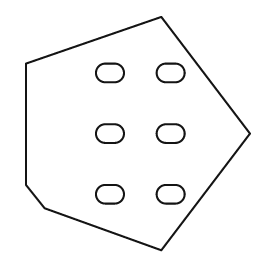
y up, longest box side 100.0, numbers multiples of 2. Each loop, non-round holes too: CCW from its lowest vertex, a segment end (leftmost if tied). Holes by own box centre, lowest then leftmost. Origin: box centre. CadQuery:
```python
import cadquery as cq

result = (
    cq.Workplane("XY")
    .moveTo(10.0, -50.0)
    .lineTo(48.0, 0.0)
    .lineTo(10.0, 50.0)
    .lineTo(-48.0, 30.0)
    .lineTo(-48.0, -22.0)
    .lineTo(-40.0, -32.0)
    .close()
    .moveTo(-14.0, -30.0)
    .lineTo(-10.0, -30.0)
    .threePointArc((-6.0, -26.0), (-10.0, -22.0))
    .lineTo(-14.0, -22.0)
    .threePointArc((-18.0, -26.0), (-14.0, -30.0))
    .close()
    .moveTo(12.0, -30.0)
    .lineTo(16.0, -30.0)
    .threePointArc((20.0, -26.0), (16.0, -22.0))
    .lineTo(12.0, -22.0)
    .threePointArc((8.0, -26.0), (12.0, -30.0))
    .close()
    .moveTo(-14.0, -4.0)
    .lineTo(-10.0, -4.0)
    .threePointArc((-6.0, 0.0), (-10.0, 4.0))
    .lineTo(-14.0, 4.0)
    .threePointArc((-18.0, 0.0), (-14.0, -4.0))
    .close()
    .moveTo(12.0, -4.0)
    .lineTo(16.0, -4.0)
    .threePointArc((20.0, 0.0), (16.0, 4.0))
    .lineTo(12.0, 4.0)
    .threePointArc((8.0, 0.0), (12.0, -4.0))
    .close()
    .moveTo(-14.0, 22.0)
    .lineTo(-10.0, 22.0)
    .threePointArc((-6.0, 26.0), (-10.0, 30.0))
    .lineTo(-14.0, 30.0)
    .threePointArc((-18.0, 26.0), (-14.0, 22.0))
    .close()
    .moveTo(12.0, 22.0)
    .lineTo(16.0, 22.0)
    .threePointArc((20.0, 26.0), (16.0, 30.0))
    .lineTo(12.0, 30.0)
    .threePointArc((8.0, 26.0), (12.0, 22.0))
    .close()
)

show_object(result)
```